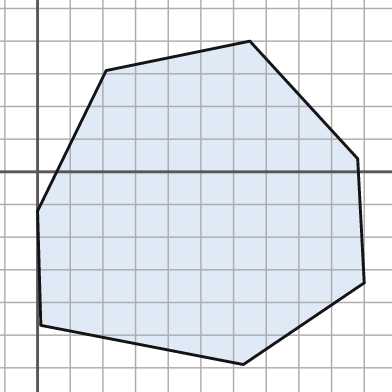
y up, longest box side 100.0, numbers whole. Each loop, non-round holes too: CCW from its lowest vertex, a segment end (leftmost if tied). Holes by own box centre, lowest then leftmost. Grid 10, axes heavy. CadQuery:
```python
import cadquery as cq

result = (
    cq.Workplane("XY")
    .moveTo(63.0, -59.0)
    .lineTo(100.0, -34.0)
    .lineTo(98.0, 4.0)
    .lineTo(65.0, 40.0)
    .lineTo(21.0, 31.0)
    .lineTo(0.0, -12.0)
    .lineTo(1.0, -47.0)
    .close()
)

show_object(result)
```